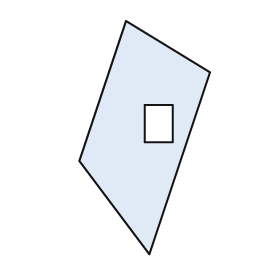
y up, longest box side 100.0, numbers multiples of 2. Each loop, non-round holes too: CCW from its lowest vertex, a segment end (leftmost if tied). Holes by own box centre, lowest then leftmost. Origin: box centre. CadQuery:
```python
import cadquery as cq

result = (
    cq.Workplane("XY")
    .moveTo(2.0, -50.0)
    .lineTo(28.0, 28.0)
    .lineTo(-8.0, 50.0)
    .lineTo(-28.0, -10.0)
    .close()
    .moveTo(0.0, -2.0)
    .lineTo(12.0, -2.0)
    .lineTo(12.0, 14.0)
    .lineTo(0.0, 14.0)
    .close()
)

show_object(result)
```